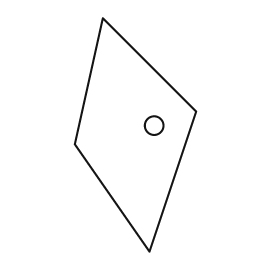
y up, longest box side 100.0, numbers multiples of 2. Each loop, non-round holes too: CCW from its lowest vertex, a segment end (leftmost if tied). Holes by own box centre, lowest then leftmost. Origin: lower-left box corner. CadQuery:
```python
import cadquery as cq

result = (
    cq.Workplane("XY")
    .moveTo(32.0, 0.0)
    .lineTo(52.0, 60.0)
    .lineTo(12.0, 100.0)
    .lineTo(0.0, 46.0)
    .close()
    .moveTo(34.0, 54.0)
    .circle(4.0)
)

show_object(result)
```